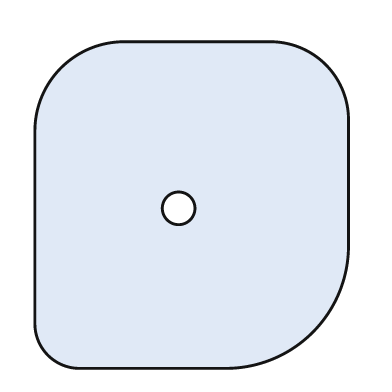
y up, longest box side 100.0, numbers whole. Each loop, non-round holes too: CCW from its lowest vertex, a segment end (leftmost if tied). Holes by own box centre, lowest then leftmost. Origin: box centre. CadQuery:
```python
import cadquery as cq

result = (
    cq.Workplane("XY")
    .moveTo(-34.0, -50.0)
    .lineTo(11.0, -50.0)
    .threePointArc((37.0, -39.0), (48.0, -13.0))
    .lineTo(48.0, 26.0)
    .threePointArc((41.0, 43.0), (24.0, 50.0))
    .lineTo(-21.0, 50.0)
    .threePointArc((-40.0, 42.0), (-48.0, 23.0))
    .lineTo(-48.0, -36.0)
    .threePointArc((-44.0, -46.0), (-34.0, -50.0))
    .close()
    .moveTo(-4.0, -1.0)
    .circle(5.0)
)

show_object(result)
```